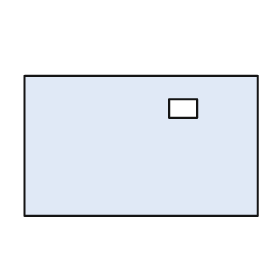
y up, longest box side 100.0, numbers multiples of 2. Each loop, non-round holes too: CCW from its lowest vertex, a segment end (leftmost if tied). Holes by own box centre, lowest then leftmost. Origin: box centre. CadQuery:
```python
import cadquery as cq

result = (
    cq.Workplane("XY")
    .moveTo(-50.0, -30.0)
    .lineTo(50.0, -30.0)
    .lineTo(50.0, 30.0)
    .lineTo(-50.0, 30.0)
    .close()
    .moveTo(12.0, 12.0)
    .lineTo(24.0, 12.0)
    .lineTo(24.0, 20.0)
    .lineTo(12.0, 20.0)
    .close()
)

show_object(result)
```